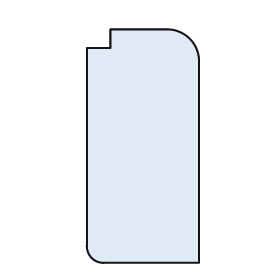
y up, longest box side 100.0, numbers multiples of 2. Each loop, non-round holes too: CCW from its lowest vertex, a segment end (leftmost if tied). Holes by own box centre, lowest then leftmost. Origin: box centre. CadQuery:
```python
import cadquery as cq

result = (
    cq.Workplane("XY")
    .moveTo(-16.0, -50.0)
    .lineTo(24.0, -50.0)
    .lineTo(24.0, 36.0)
    .threePointArc((20.0, 46.0), (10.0, 50.0))
    .lineTo(-14.0, 50.0)
    .lineTo(-14.0, 42.0)
    .lineTo(-24.0, 42.0)
    .lineTo(-24.0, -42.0)
    .threePointArc((-22.0, -48.0), (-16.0, -50.0))
    .close()
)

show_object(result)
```